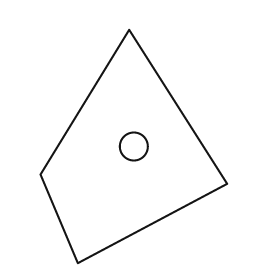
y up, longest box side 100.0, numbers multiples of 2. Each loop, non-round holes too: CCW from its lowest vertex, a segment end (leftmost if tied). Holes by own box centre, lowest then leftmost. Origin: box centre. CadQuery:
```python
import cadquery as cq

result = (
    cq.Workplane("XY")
    .moveTo(-24.0, -50.0)
    .lineTo(40.0, -16.0)
    .lineTo(-2.0, 50.0)
    .lineTo(-40.0, -12.0)
    .close()
    .moveTo(0.0, 0.0)
    .circle(6.0)
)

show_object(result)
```